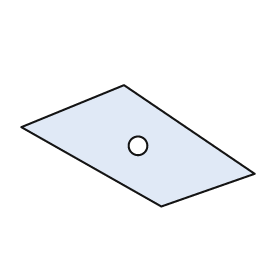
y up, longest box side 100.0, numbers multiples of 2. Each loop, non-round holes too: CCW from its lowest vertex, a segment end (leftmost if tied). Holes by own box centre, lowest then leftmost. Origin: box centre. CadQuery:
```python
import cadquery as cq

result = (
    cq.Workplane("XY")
    .moveTo(10.0, -26.0)
    .lineTo(50.0, -12.0)
    .lineTo(-6.0, 26.0)
    .lineTo(-50.0, 8.0)
    .close()
    .moveTo(0.0, 0.0)
    .circle(4.0)
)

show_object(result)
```